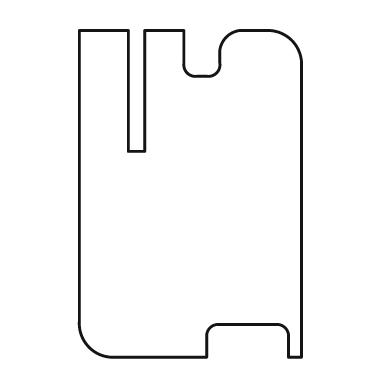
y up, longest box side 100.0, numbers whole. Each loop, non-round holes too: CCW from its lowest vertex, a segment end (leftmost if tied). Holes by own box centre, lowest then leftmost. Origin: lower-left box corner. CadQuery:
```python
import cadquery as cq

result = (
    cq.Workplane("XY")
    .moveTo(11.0, 0.0)
    .lineTo(39.0, 0.0)
    .lineTo(39.0, 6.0)
    .threePointArc((40.0, 9.0), (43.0, 10.0))
    .lineTo(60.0, 10.0)
    .threePointArc((63.0, 9.0), (64.0, 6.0))
    .lineTo(64.0, 0.0)
    .lineTo(68.0, 0.0)
    .lineTo(68.0, 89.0)
    .threePointArc((65.0, 97.0), (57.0, 100.0))
    .lineTo(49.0, 100.0)
    .threePointArc((45.0, 98.0), (43.0, 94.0))
    .lineTo(43.0, 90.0)
    .threePointArc((42.0, 87.0), (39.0, 86.0))
    .lineTo(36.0, 86.0)
    .threePointArc((33.0, 87.0), (32.0, 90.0))
    .lineTo(32.0, 100.0)
    .lineTo(20.0, 100.0)
    .lineTo(20.0, 63.0)
    .lineTo(15.0, 63.0)
    .lineTo(15.0, 100.0)
    .lineTo(0.0, 100.0)
    .lineTo(0.0, 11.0)
    .threePointArc((3.0, 3.0), (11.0, 0.0))
    .close()
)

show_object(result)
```